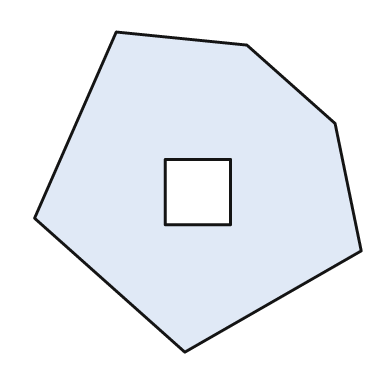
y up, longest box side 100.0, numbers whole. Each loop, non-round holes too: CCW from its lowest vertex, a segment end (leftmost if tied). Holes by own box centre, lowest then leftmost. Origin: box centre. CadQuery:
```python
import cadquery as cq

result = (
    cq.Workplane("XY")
    .moveTo(-4.0, -49.0)
    .lineTo(50.0, -18.0)
    .lineTo(42.0, 21.0)
    .lineTo(15.0, 45.0)
    .lineTo(-25.0, 49.0)
    .lineTo(-50.0, -8.0)
    .close()
    .moveTo(-10.0, -10.0)
    .lineTo(10.0, -10.0)
    .lineTo(10.0, 10.0)
    .lineTo(-10.0, 10.0)
    .close()
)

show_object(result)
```